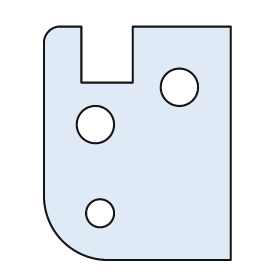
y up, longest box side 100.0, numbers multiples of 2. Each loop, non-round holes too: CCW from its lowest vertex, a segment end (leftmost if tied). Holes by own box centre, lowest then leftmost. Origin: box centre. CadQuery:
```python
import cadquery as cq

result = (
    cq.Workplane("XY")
    .moveTo(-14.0, -50.0)
    .lineTo(40.0, -50.0)
    .lineTo(40.0, 50.0)
    .lineTo(-2.0, 50.0)
    .lineTo(-2.0, 26.0)
    .lineTo(-24.0, 26.0)
    .lineTo(-24.0, 50.0)
    .lineTo(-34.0, 50.0)
    .threePointArc((-38.0, 48.0), (-40.0, 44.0))
    .lineTo(-40.0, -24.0)
    .threePointArc((-32.0, -42.0), (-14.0, -50.0))
    .close()
    .moveTo(-16.0, -30.0)
    .circle(6.0)
    .moveTo(-18.0, 8.0)
    .circle(8.0)
    .moveTo(18.0, 24.0)
    .circle(8.0)
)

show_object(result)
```